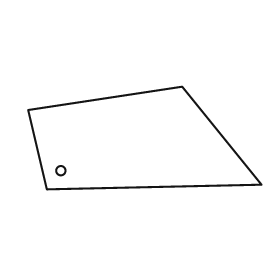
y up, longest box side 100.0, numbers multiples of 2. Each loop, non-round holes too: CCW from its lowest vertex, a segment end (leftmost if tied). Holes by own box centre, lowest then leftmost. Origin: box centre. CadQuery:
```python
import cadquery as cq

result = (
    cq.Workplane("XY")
    .moveTo(-42.0, -22.0)
    .lineTo(50.0, -20.0)
    .lineTo(16.0, 22.0)
    .lineTo(-50.0, 12.0)
    .close()
    .moveTo(-36.0, -14.0)
    .circle(2.0)
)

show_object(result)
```